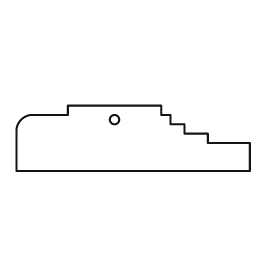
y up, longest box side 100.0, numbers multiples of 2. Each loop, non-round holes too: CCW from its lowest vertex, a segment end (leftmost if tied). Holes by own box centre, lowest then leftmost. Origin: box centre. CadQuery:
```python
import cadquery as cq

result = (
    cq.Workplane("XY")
    .moveTo(-50.0, -14.0)
    .lineTo(50.0, -14.0)
    .lineTo(50.0, -2.0)
    .lineTo(32.0, -2.0)
    .lineTo(32.0, 2.0)
    .lineTo(22.0, 2.0)
    .lineTo(22.0, 6.0)
    .lineTo(16.0, 6.0)
    .lineTo(16.0, 10.0)
    .lineTo(12.0, 10.0)
    .lineTo(12.0, 14.0)
    .lineTo(-28.0, 14.0)
    .lineTo(-28.0, 10.0)
    .lineTo(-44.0, 10.0)
    .threePointArc((-48.0, 8.0), (-50.0, 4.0))
    .close()
    .moveTo(-8.0, 8.0)
    .circle(2.0)
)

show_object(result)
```